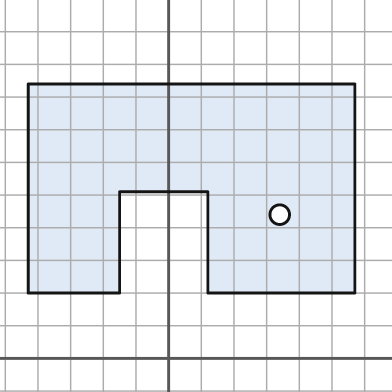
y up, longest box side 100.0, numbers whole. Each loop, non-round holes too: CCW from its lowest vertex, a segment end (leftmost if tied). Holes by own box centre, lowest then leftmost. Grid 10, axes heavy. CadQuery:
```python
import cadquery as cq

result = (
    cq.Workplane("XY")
    .moveTo(-43.0, 20.0)
    .lineTo(-15.0, 20.0)
    .lineTo(-15.0, 51.0)
    .lineTo(12.0, 51.0)
    .lineTo(12.0, 20.0)
    .lineTo(57.0, 20.0)
    .lineTo(57.0, 84.0)
    .lineTo(-43.0, 84.0)
    .close()
    .moveTo(34.0, 44.0)
    .circle(3.0)
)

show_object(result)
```